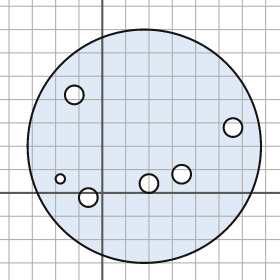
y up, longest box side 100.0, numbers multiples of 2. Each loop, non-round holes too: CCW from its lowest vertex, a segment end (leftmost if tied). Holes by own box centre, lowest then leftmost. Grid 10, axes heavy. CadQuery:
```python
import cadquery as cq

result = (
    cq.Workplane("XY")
    .moveTo(18.0, 20.0)
    .circle(50.0)
    .moveTo(-6.0, -2.0)
    .circle(4.0)
    .moveTo(20.0, 4.0)
    .circle(4.0)
    .moveTo(-18.0, 6.0)
    .circle(2.0)
    .moveTo(34.0, 8.0)
    .circle(4.0)
    .moveTo(56.0, 28.0)
    .circle(4.0)
    .moveTo(-12.0, 42.0)
    .circle(4.0)
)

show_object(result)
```